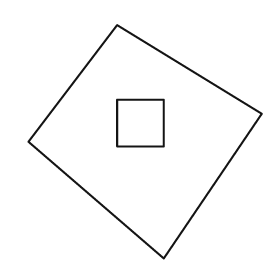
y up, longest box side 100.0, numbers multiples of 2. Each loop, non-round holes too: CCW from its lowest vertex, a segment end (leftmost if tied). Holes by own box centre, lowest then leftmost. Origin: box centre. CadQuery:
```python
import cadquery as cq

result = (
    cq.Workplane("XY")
    .moveTo(8.0, -50.0)
    .lineTo(50.0, 12.0)
    .lineTo(-12.0, 50.0)
    .lineTo(-50.0, 0.0)
    .close()
    .moveTo(-12.0, -2.0)
    .lineTo(8.0, -2.0)
    .lineTo(8.0, 18.0)
    .lineTo(-12.0, 18.0)
    .close()
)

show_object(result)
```